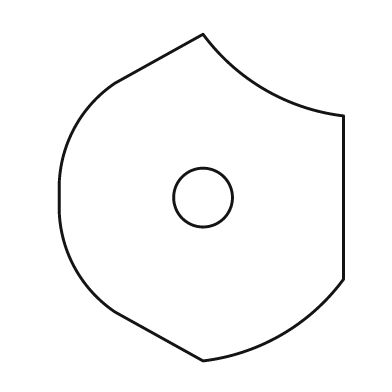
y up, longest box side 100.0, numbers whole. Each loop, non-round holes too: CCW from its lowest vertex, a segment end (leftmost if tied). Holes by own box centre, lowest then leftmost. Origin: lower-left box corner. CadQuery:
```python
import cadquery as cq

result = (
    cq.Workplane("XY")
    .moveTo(44.0, 0.0)
    .threePointArc((68.0, 8.0), (87.0, 25.0))
    .lineTo(87.0, 75.0)
    .threePointArc((63.0, 83.0), (44.0, 100.0))
    .lineTo(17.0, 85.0)
    .threePointArc((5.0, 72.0), (0.0, 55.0))
    .lineTo(0.0, 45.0)
    .threePointArc((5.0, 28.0), (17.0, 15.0))
    .close()
    .moveTo(44.0, 50.0)
    .circle(9.0)
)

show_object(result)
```